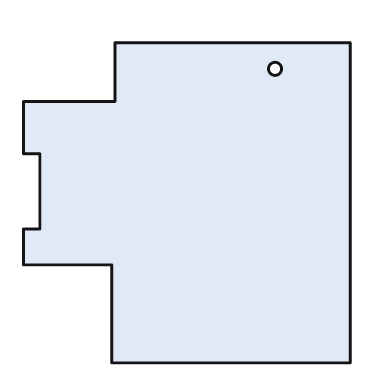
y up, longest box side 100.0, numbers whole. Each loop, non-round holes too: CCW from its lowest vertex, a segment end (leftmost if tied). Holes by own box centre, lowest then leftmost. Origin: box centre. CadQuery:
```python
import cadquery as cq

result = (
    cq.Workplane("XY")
    .moveTo(-23.0, -49.0)
    .lineTo(50.0, -49.0)
    .lineTo(50.0, 49.0)
    .lineTo(-22.0, 49.0)
    .lineTo(-22.0, 31.0)
    .lineTo(-50.0, 31.0)
    .lineTo(-50.0, 15.0)
    .lineTo(-45.0, 15.0)
    .lineTo(-45.0, -8.0)
    .lineTo(-50.0, -8.0)
    .lineTo(-50.0, -19.0)
    .lineTo(-23.0, -19.0)
    .close()
    .moveTo(27.0, 41.0)
    .circle(2.0)
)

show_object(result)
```